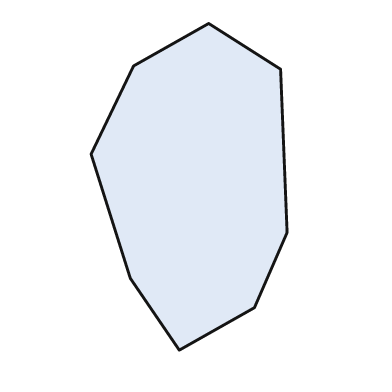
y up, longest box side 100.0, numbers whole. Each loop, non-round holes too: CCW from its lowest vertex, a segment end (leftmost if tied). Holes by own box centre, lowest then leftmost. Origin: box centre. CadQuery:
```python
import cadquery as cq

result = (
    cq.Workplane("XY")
    .moveTo(-3.0, -50.0)
    .lineTo(20.0, -37.0)
    .lineTo(30.0, -14.0)
    .lineTo(28.0, 36.0)
    .lineTo(6.0, 50.0)
    .lineTo(-17.0, 37.0)
    .lineTo(-30.0, 10.0)
    .lineTo(-18.0, -28.0)
    .close()
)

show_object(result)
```